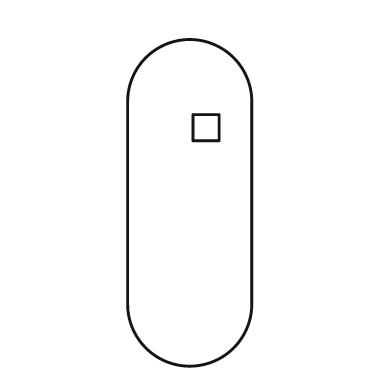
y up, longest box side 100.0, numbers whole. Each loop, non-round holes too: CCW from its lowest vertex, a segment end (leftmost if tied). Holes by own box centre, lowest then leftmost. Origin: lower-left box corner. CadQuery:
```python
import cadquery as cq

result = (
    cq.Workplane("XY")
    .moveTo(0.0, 19.0)
    .threePointArc((19.0, 0.0), (38.0, 19.0))
    .lineTo(38.0, 81.0)
    .threePointArc((19.0, 100.0), (0.0, 81.0))
    .close()
    .moveTo(20.0, 69.0)
    .lineTo(28.0, 69.0)
    .lineTo(28.0, 77.0)
    .lineTo(20.0, 77.0)
    .close()
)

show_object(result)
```